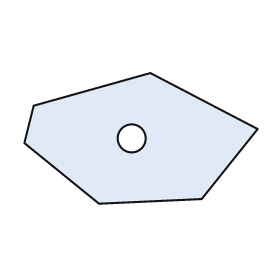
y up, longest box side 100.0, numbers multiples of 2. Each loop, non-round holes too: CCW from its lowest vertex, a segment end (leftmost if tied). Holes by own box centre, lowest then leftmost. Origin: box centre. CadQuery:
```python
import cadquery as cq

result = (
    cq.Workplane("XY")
    .moveTo(-18.0, -28.0)
    .lineTo(26.0, -26.0)
    .lineTo(50.0, 4.0)
    .lineTo(4.0, 28.0)
    .lineTo(-46.0, 14.0)
    .lineTo(-50.0, -2.0)
    .close()
    .moveTo(-4.0, 0.0)
    .circle(6.0)
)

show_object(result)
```